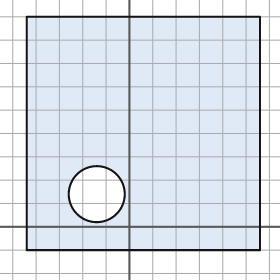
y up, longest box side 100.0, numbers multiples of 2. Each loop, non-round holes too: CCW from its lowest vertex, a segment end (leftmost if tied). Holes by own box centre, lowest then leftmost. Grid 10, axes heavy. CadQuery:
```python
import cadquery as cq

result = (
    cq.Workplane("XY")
    .moveTo(-44.0, -10.0)
    .lineTo(56.0, -10.0)
    .lineTo(56.0, 90.0)
    .lineTo(-44.0, 90.0)
    .close()
    .moveTo(-14.0, 14.0)
    .circle(12.0)
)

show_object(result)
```